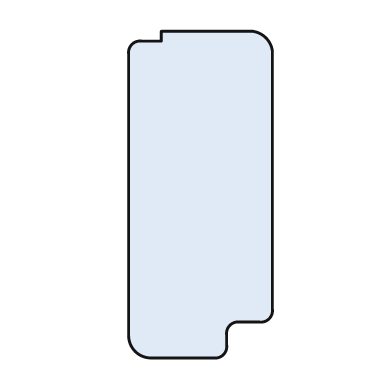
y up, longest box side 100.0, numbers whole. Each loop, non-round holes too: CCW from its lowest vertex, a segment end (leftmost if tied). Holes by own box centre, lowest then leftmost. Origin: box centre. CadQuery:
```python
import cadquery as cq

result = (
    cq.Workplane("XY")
    .moveTo(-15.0, -50.0)
    .lineTo(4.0, -50.0)
    .threePointArc((7.0, -49.0), (8.0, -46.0))
    .lineTo(8.0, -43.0)
    .threePointArc((9.0, -40.0), (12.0, -39.0))
    .lineTo(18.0, -39.0)
    .threePointArc((21.0, -38.0), (22.0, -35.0))
    .lineTo(22.0, 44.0)
    .threePointArc((20.0, 48.0), (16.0, 50.0))
    .lineTo(-12.0, 50.0)
    .lineTo(-12.0, 47.0)
    .lineTo(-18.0, 47.0)
    .threePointArc((-21.0, 46.0), (-22.0, 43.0))
    .lineTo(-22.0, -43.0)
    .threePointArc((-20.0, -48.0), (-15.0, -50.0))
    .close()
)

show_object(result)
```